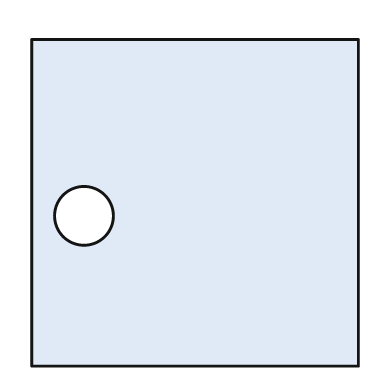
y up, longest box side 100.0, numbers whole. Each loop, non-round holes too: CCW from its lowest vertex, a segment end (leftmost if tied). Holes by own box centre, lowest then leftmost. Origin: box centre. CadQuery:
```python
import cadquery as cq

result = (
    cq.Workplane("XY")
    .moveTo(-50.0, -50.0)
    .lineTo(50.0, -50.0)
    .lineTo(50.0, 50.0)
    .lineTo(-50.0, 50.0)
    .close()
    .moveTo(-34.0, -4.0)
    .circle(9.0)
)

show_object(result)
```